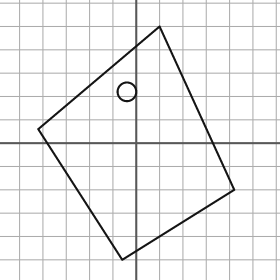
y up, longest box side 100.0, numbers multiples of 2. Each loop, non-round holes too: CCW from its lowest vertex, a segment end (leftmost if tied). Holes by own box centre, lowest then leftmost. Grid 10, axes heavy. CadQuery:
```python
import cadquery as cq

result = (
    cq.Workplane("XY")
    .moveTo(-6.0, -50.0)
    .lineTo(42.0, -20.0)
    .lineTo(10.0, 50.0)
    .lineTo(-42.0, 6.0)
    .close()
    .moveTo(-4.0, 22.0)
    .circle(4.0)
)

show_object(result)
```